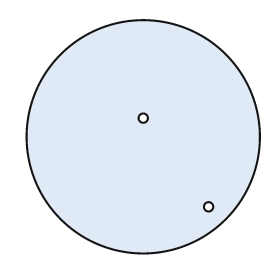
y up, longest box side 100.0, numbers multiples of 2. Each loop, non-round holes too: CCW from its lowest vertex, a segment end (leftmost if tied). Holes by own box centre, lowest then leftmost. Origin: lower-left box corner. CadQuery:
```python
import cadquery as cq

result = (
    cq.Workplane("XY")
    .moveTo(50.0, 50.0)
    .circle(50.0)
    .moveTo(78.0, 20.0)
    .circle(2.0)
    .moveTo(50.0, 58.0)
    .circle(2.0)
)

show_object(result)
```